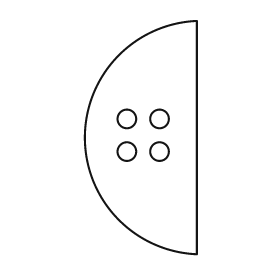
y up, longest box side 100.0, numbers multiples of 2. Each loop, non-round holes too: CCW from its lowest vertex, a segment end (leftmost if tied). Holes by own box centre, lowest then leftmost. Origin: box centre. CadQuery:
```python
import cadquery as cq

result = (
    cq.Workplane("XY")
    .moveTo(24.0, -50.0)
    .lineTo(24.0, 50.0)
    .threePointArc((-24.0, 0.0), (24.0, -50.0))
    .close()
    .moveTo(-6.0, -6.0)
    .circle(4.0)
    .moveTo(8.0, -6.0)
    .circle(4.0)
    .moveTo(-6.0, 8.0)
    .circle(4.0)
    .moveTo(8.0, 8.0)
    .circle(4.0)
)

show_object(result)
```